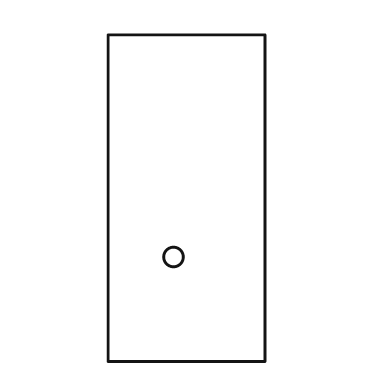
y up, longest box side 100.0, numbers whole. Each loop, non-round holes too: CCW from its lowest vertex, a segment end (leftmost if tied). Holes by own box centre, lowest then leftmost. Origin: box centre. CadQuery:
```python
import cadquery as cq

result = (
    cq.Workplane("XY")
    .moveTo(-24.0, -50.0)
    .lineTo(24.0, -50.0)
    .lineTo(24.0, 50.0)
    .lineTo(-24.0, 50.0)
    .close()
    .moveTo(-4.0, -18.0)
    .circle(3.0)
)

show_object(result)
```